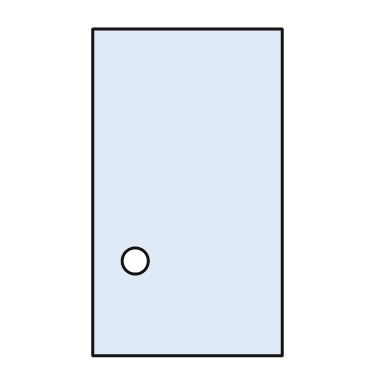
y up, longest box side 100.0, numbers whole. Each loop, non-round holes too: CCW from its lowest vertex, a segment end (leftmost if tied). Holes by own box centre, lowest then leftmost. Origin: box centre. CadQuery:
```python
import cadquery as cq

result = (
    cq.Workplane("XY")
    .moveTo(-29.0, -50.0)
    .lineTo(29.0, -50.0)
    .lineTo(29.0, 50.0)
    .lineTo(-29.0, 50.0)
    .close()
    .moveTo(-16.0, -21.0)
    .circle(4.0)
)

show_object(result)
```